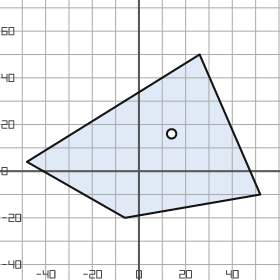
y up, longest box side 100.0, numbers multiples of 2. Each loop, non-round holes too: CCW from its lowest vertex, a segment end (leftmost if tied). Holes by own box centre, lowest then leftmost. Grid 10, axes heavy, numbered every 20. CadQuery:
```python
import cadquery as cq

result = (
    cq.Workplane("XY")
    .moveTo(-6.0, -20.0)
    .lineTo(52.0, -10.0)
    .lineTo(26.0, 50.0)
    .lineTo(-48.0, 4.0)
    .close()
    .moveTo(14.0, 16.0)
    .circle(2.0)
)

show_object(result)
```